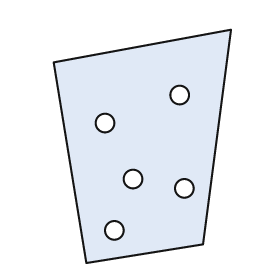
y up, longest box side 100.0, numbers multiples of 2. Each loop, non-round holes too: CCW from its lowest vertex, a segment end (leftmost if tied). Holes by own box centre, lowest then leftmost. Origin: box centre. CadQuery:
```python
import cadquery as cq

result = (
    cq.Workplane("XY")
    .moveTo(-24.0, -50.0)
    .lineTo(26.0, -42.0)
    .lineTo(38.0, 50.0)
    .lineTo(-38.0, 36.0)
    .close()
    .moveTo(-12.0, -36.0)
    .circle(4.0)
    .moveTo(18.0, -18.0)
    .circle(4.0)
    .moveTo(-4.0, -14.0)
    .circle(4.0)
    .moveTo(-16.0, 10.0)
    .circle(4.0)
    .moveTo(16.0, 22.0)
    .circle(4.0)
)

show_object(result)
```